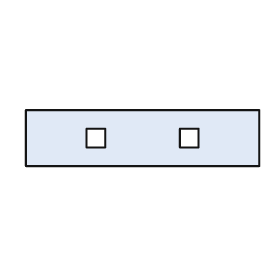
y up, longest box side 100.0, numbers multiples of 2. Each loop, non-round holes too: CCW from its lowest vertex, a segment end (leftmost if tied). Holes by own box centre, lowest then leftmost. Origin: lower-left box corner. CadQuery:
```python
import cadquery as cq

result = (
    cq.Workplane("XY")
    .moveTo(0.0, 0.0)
    .lineTo(100.0, 0.0)
    .lineTo(100.0, 24.0)
    .lineTo(0.0, 24.0)
    .close()
    .moveTo(26.0, 8.0)
    .lineTo(34.0, 8.0)
    .lineTo(34.0, 16.0)
    .lineTo(26.0, 16.0)
    .close()
    .moveTo(66.0, 8.0)
    .lineTo(74.0, 8.0)
    .lineTo(74.0, 16.0)
    .lineTo(66.0, 16.0)
    .close()
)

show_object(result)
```